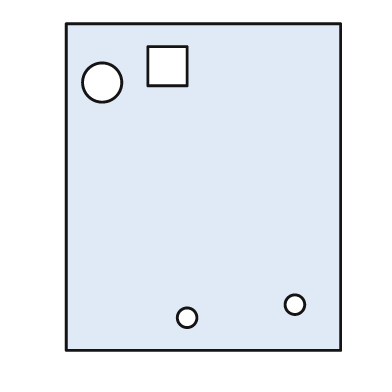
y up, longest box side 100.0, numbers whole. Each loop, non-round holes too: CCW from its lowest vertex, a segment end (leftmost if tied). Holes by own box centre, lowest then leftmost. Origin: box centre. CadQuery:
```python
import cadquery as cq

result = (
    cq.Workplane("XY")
    .moveTo(-42.0, -50.0)
    .lineTo(42.0, -50.0)
    .lineTo(42.0, 50.0)
    .lineTo(-42.0, 50.0)
    .close()
    .moveTo(-5.0, -40.0)
    .circle(3.0)
    .moveTo(28.0, -36.0)
    .circle(3.0)
    .moveTo(-31.0, 32.0)
    .circle(6.0)
    .moveTo(-17.0, 31.0)
    .lineTo(-5.0, 31.0)
    .lineTo(-5.0, 43.0)
    .lineTo(-17.0, 43.0)
    .close()
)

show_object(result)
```